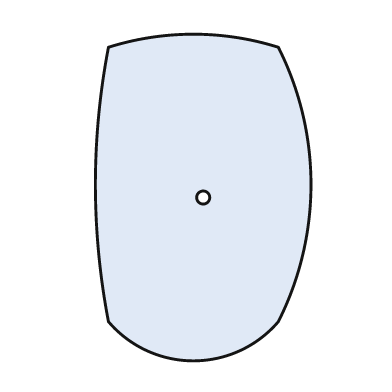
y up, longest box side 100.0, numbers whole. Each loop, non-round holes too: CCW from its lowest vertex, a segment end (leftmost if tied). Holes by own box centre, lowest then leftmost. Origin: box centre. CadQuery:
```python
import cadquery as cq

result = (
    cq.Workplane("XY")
    .moveTo(-29.0, -38.0)
    .threePointArc((-3.0, -50.0), (23.0, -38.0))
    .threePointArc((33.0, 4.0), (23.0, 46.0))
    .threePointArc((-3.0, 50.0), (-29.0, 46.0))
    .threePointArc((-33.0, 4.0), (-29.0, -38.0))
    .close()
    .moveTo(0.0, 0.0)
    .circle(2.0)
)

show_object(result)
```